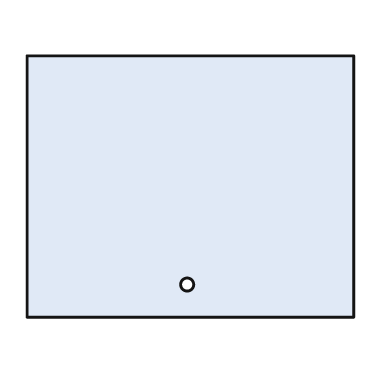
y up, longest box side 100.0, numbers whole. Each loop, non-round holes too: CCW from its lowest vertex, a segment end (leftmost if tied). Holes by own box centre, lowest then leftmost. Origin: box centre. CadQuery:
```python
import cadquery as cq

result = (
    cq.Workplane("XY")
    .moveTo(-50.0, -40.0)
    .lineTo(50.0, -40.0)
    .lineTo(50.0, 40.0)
    .lineTo(-50.0, 40.0)
    .close()
    .moveTo(-1.0, -30.0)
    .circle(2.0)
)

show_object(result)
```